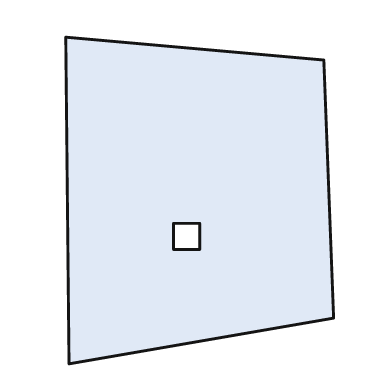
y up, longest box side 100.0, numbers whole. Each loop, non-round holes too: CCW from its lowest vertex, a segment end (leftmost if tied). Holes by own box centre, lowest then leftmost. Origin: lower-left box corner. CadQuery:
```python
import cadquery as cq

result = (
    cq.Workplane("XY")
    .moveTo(1.0, 0.0)
    .lineTo(82.0, 14.0)
    .lineTo(79.0, 93.0)
    .lineTo(0.0, 100.0)
    .close()
    .moveTo(33.0, 35.0)
    .lineTo(41.0, 35.0)
    .lineTo(41.0, 43.0)
    .lineTo(33.0, 43.0)
    .close()
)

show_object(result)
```